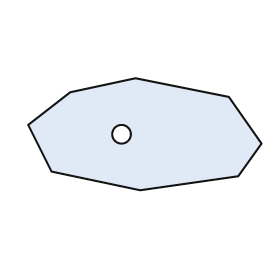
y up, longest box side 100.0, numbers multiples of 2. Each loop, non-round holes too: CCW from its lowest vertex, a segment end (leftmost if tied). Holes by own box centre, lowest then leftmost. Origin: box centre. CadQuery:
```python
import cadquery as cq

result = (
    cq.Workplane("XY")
    .moveTo(-2.0, -24.0)
    .lineTo(40.0, -18.0)
    .lineTo(50.0, -4.0)
    .lineTo(36.0, 16.0)
    .lineTo(-4.0, 24.0)
    .lineTo(-32.0, 18.0)
    .lineTo(-50.0, 4.0)
    .lineTo(-40.0, -16.0)
    .close()
    .moveTo(-10.0, 0.0)
    .circle(4.0)
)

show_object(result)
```